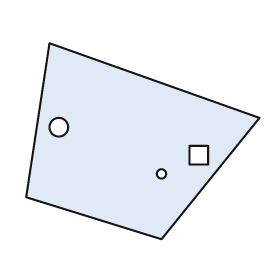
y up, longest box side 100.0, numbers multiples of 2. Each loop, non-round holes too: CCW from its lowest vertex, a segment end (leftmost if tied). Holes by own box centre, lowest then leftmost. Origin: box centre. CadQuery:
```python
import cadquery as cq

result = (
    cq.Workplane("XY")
    .moveTo(8.0, -42.0)
    .lineTo(50.0, 10.0)
    .lineTo(-40.0, 42.0)
    .lineTo(-50.0, -24.0)
    .close()
    .moveTo(8.0, -14.0)
    .circle(2.0)
    .moveTo(20.0, -10.0)
    .lineTo(28.0, -10.0)
    .lineTo(28.0, -2.0)
    .lineTo(20.0, -2.0)
    .close()
    .moveTo(-36.0, 6.0)
    .circle(4.0)
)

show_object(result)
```